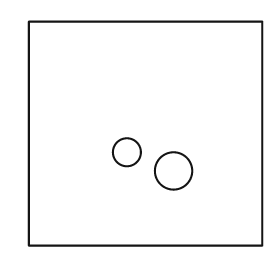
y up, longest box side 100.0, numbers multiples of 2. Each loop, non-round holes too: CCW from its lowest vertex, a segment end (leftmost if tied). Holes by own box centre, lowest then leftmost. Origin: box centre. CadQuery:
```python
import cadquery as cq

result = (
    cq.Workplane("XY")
    .moveTo(-50.0, -48.0)
    .lineTo(50.0, -48.0)
    .lineTo(50.0, 48.0)
    .lineTo(-50.0, 48.0)
    .close()
    .moveTo(12.0, -16.0)
    .circle(8.0)
    .moveTo(-8.0, -8.0)
    .circle(6.0)
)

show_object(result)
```